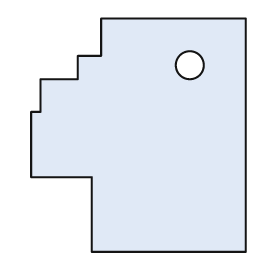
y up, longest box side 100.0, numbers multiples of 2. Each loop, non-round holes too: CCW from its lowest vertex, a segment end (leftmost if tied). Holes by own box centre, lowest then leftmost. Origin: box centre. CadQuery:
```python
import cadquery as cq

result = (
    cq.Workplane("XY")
    .moveTo(-20.0, -50.0)
    .lineTo(46.0, -50.0)
    .lineTo(46.0, 50.0)
    .lineTo(-16.0, 50.0)
    .lineTo(-16.0, 34.0)
    .lineTo(-26.0, 34.0)
    .lineTo(-26.0, 24.0)
    .lineTo(-42.0, 24.0)
    .lineTo(-42.0, 10.0)
    .lineTo(-46.0, 10.0)
    .lineTo(-46.0, -18.0)
    .lineTo(-20.0, -18.0)
    .close()
    .moveTo(22.0, 30.0)
    .circle(6.0)
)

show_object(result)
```